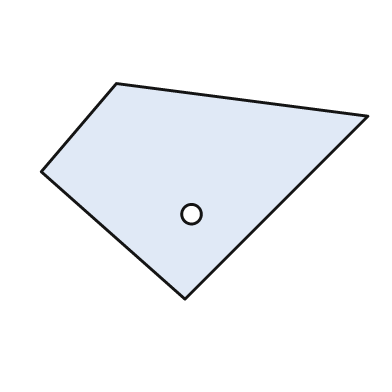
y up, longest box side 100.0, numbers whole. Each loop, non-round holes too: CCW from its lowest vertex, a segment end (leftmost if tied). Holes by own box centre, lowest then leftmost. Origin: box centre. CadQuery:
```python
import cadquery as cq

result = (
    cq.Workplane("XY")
    .moveTo(-6.0, -33.0)
    .lineTo(50.0, 23.0)
    .lineTo(-27.0, 33.0)
    .lineTo(-50.0, 6.0)
    .close()
    .moveTo(-4.0, -7.0)
    .circle(3.0)
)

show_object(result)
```